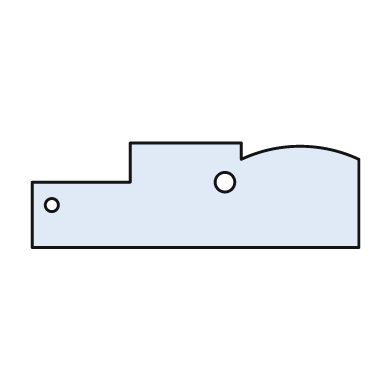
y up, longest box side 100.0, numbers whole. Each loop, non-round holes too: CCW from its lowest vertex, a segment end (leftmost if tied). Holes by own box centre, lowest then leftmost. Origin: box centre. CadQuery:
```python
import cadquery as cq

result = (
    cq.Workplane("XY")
    .moveTo(-50.0, -16.0)
    .lineTo(50.0, -16.0)
    .lineTo(50.0, 11.0)
    .threePointArc((32.0, 15.0), (14.0, 11.0))
    .lineTo(14.0, 16.0)
    .lineTo(-20.0, 16.0)
    .lineTo(-20.0, 4.0)
    .lineTo(-50.0, 4.0)
    .close()
    .moveTo(-44.0, -3.0)
    .circle(2.0)
    .moveTo(9.0, 4.0)
    .circle(3.0)
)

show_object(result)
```